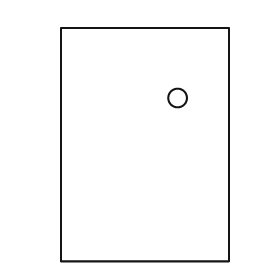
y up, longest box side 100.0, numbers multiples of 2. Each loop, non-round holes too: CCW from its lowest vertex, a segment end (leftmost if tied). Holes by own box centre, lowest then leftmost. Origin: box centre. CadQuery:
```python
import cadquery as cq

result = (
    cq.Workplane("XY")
    .moveTo(-36.0, -50.0)
    .lineTo(36.0, -50.0)
    .lineTo(36.0, 50.0)
    .lineTo(-36.0, 50.0)
    .close()
    .moveTo(14.0, 20.0)
    .circle(4.0)
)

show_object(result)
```